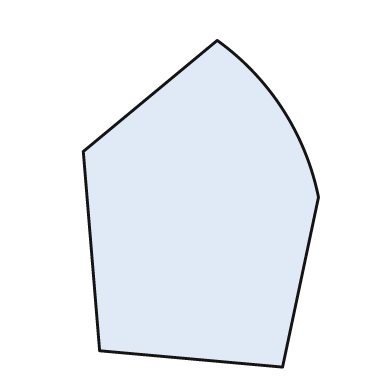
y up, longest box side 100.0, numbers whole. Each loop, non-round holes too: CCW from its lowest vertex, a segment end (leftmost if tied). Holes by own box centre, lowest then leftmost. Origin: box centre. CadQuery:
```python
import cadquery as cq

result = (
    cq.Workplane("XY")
    .moveTo(25.0, -50.0)
    .lineTo(36.0, 2.0)
    .threePointArc((25.0, 29.0), (5.0, 50.0))
    .lineTo(-36.0, 16.0)
    .lineTo(-31.0, -45.0)
    .close()
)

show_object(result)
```